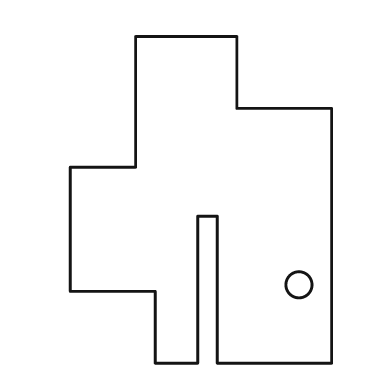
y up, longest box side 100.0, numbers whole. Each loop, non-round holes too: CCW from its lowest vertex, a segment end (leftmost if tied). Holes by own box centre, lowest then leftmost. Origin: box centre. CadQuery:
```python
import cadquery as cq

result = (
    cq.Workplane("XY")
    .moveTo(-14.0, -50.0)
    .lineTo(-1.0, -50.0)
    .lineTo(-1.0, -5.0)
    .lineTo(5.0, -5.0)
    .lineTo(5.0, -50.0)
    .lineTo(40.0, -50.0)
    .lineTo(40.0, 28.0)
    .lineTo(11.0, 28.0)
    .lineTo(11.0, 50.0)
    .lineTo(-20.0, 50.0)
    .lineTo(-20.0, 10.0)
    .lineTo(-40.0, 10.0)
    .lineTo(-40.0, -28.0)
    .lineTo(-14.0, -28.0)
    .close()
    .moveTo(30.0, -26.0)
    .circle(4.0)
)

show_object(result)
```